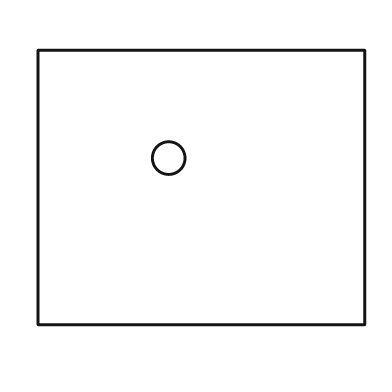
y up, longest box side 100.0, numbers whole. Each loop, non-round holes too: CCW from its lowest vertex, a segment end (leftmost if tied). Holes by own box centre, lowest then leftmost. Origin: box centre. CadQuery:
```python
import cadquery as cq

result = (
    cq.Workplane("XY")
    .moveTo(-50.0, -42.0)
    .lineTo(50.0, -42.0)
    .lineTo(50.0, 42.0)
    .lineTo(-50.0, 42.0)
    .close()
    .moveTo(-10.0, 9.0)
    .circle(5.0)
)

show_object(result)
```